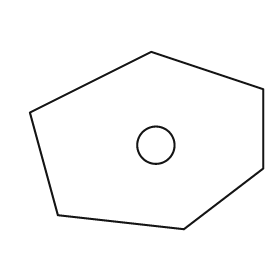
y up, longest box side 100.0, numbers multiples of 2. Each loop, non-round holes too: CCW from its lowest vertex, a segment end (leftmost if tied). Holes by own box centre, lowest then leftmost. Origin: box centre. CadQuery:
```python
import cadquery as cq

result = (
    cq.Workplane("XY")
    .moveTo(16.0, -38.0)
    .lineTo(50.0, -12.0)
    .lineTo(50.0, 22.0)
    .lineTo(2.0, 38.0)
    .lineTo(-50.0, 12.0)
    .lineTo(-38.0, -32.0)
    .close()
    .moveTo(4.0, -2.0)
    .circle(8.0)
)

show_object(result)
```